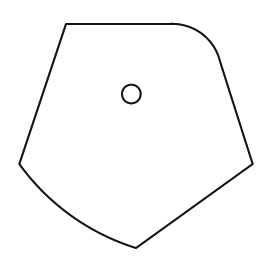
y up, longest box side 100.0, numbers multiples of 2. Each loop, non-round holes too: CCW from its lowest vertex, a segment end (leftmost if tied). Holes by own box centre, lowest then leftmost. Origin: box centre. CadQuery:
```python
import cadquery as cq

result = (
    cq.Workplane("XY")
    .moveTo(0.0, -48.0)
    .lineTo(50.0, -12.0)
    .lineTo(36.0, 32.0)
    .threePointArc((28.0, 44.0), (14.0, 48.0))
    .lineTo(-30.0, 48.0)
    .lineTo(-50.0, -12.0)
    .threePointArc((-28.0, -34.0), (0.0, -48.0))
    .close()
    .moveTo(-2.0, 18.0)
    .circle(4.0)
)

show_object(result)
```